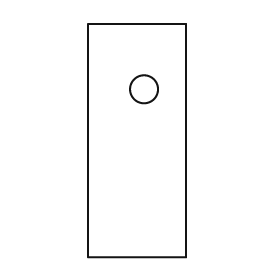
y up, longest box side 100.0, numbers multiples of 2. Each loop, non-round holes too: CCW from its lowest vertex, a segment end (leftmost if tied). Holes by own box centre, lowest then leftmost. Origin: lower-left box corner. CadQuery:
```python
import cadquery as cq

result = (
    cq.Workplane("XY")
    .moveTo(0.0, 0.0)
    .lineTo(42.0, 0.0)
    .lineTo(42.0, 100.0)
    .lineTo(0.0, 100.0)
    .close()
    .moveTo(24.0, 72.0)
    .circle(6.0)
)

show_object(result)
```